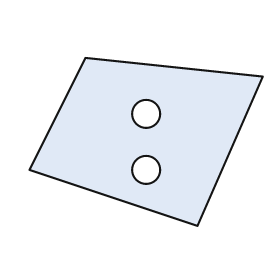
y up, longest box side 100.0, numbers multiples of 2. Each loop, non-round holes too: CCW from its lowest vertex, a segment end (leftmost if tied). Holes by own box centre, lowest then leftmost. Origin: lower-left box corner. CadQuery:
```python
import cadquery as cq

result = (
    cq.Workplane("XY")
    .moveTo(72.0, 0.0)
    .lineTo(100.0, 64.0)
    .lineTo(24.0, 72.0)
    .lineTo(0.0, 24.0)
    .close()
    .moveTo(50.0, 24.0)
    .circle(6.0)
    .moveTo(50.0, 48.0)
    .circle(6.0)
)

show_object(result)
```